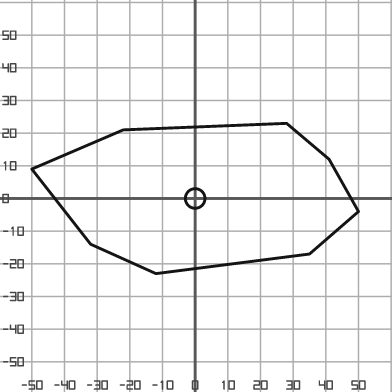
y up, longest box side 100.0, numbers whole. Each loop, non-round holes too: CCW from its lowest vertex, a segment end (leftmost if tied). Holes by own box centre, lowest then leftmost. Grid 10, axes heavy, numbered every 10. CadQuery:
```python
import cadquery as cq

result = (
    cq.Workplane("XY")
    .moveTo(-12.0, -23.0)
    .lineTo(35.0, -17.0)
    .lineTo(50.0, -4.0)
    .lineTo(41.0, 12.0)
    .lineTo(28.0, 23.0)
    .lineTo(-22.0, 21.0)
    .lineTo(-50.0, 9.0)
    .lineTo(-32.0, -14.0)
    .close()
    .moveTo(0.0, 0.0)
    .circle(3.0)
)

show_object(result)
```